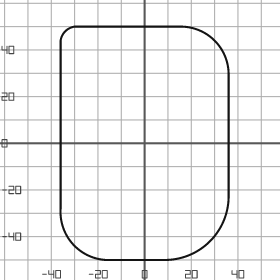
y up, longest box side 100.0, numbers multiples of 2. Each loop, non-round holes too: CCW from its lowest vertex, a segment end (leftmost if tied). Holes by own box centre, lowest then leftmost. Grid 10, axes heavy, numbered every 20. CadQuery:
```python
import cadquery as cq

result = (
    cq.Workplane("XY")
    .moveTo(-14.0, -50.0)
    .lineTo(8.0, -50.0)
    .threePointArc((28.0, -42.0), (36.0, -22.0))
    .lineTo(36.0, 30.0)
    .threePointArc((30.0, 44.0), (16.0, 50.0))
    .lineTo(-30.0, 50.0)
    .threePointArc((-34.0, 48.0), (-36.0, 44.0))
    .lineTo(-36.0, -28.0)
    .threePointArc((-30.0, -44.0), (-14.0, -50.0))
    .close()
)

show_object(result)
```